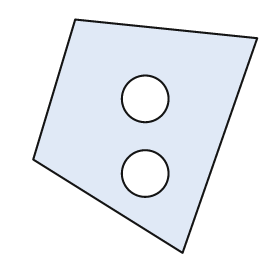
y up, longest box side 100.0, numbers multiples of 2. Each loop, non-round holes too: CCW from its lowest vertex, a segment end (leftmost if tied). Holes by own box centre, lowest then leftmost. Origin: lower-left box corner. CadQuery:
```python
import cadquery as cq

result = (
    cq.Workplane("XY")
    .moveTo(64.0, 0.0)
    .lineTo(96.0, 92.0)
    .lineTo(18.0, 100.0)
    .lineTo(0.0, 40.0)
    .close()
    .moveTo(48.0, 34.0)
    .circle(10.0)
    .moveTo(48.0, 66.0)
    .circle(10.0)
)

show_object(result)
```